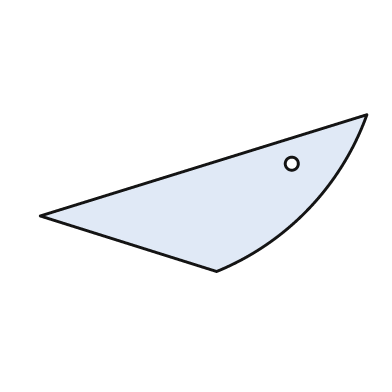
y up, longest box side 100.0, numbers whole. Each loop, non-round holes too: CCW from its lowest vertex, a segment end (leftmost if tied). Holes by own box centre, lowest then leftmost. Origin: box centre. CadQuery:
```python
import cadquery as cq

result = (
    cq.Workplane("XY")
    .moveTo(4.0, -24.0)
    .threePointArc((32.0, -5.0), (50.0, 24.0))
    .lineTo(-50.0, -7.0)
    .close()
    .moveTo(27.0, 9.0)
    .circle(2.0)
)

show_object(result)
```